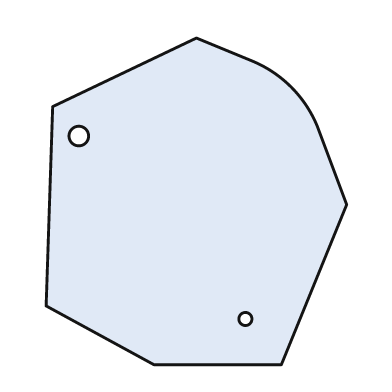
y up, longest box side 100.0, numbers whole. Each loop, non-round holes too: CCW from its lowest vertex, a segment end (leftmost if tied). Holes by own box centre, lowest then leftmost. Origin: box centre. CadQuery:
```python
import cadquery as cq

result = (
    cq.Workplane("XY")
    .moveTo(-13.0, -50.0)
    .lineTo(26.0, -50.0)
    .lineTo(46.0, -1.0)
    .lineTo(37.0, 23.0)
    .threePointArc((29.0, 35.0), (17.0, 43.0))
    .lineTo(0.0, 50.0)
    .lineTo(-44.0, 29.0)
    .lineTo(-46.0, -32.0)
    .close()
    .moveTo(15.0, -36.0)
    .circle(2.0)
    .moveTo(-36.0, 20.0)
    .circle(3.0)
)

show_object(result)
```